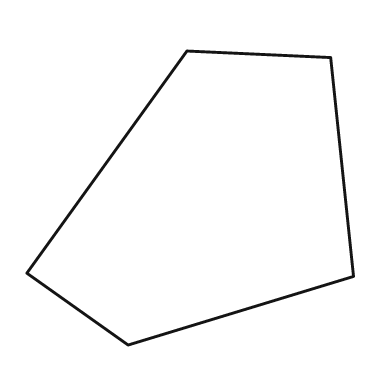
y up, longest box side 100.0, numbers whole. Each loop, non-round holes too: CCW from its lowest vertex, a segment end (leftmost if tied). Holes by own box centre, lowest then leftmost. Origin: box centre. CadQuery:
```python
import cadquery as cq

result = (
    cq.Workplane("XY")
    .moveTo(-19.0, -45.0)
    .lineTo(50.0, -24.0)
    .lineTo(43.0, 43.0)
    .lineTo(-1.0, 45.0)
    .lineTo(-50.0, -23.0)
    .close()
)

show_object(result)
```